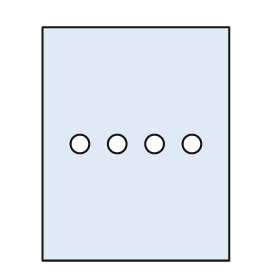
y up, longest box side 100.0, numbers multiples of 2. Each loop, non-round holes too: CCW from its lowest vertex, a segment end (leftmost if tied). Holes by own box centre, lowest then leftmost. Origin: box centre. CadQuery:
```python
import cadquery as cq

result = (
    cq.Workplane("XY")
    .moveTo(-40.0, -50.0)
    .lineTo(40.0, -50.0)
    .lineTo(40.0, 50.0)
    .lineTo(-40.0, 50.0)
    .close()
    .moveTo(-24.0, 0.0)
    .circle(4.0)
    .moveTo(-8.0, 0.0)
    .circle(4.0)
    .moveTo(8.0, 0.0)
    .circle(4.0)
    .moveTo(24.0, 0.0)
    .circle(4.0)
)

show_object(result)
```